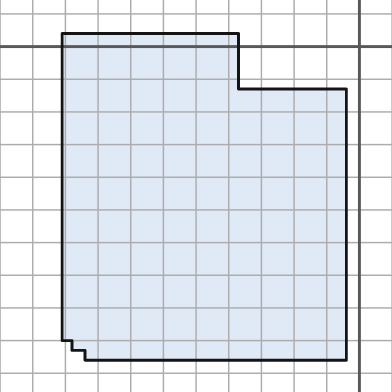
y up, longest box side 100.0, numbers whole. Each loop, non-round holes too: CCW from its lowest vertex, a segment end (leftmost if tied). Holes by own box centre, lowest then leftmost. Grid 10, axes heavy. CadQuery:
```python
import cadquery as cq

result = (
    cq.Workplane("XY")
    .moveTo(-84.0, -96.0)
    .lineTo(-4.0, -96.0)
    .lineTo(-4.0, -13.0)
    .lineTo(-37.0, -13.0)
    .lineTo(-37.0, 4.0)
    .lineTo(-91.0, 4.0)
    .lineTo(-91.0, -90.0)
    .lineTo(-88.0, -90.0)
    .lineTo(-88.0, -93.0)
    .lineTo(-84.0, -93.0)
    .close()
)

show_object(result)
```